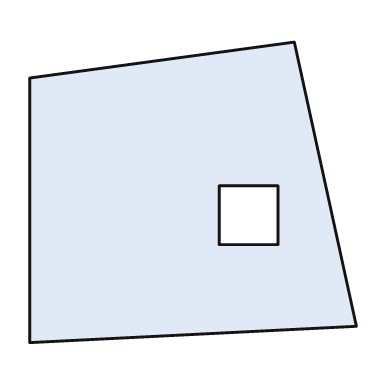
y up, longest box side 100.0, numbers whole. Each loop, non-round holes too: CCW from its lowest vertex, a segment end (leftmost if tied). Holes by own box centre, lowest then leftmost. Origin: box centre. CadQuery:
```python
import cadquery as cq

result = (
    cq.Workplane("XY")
    .moveTo(-50.0, -46.0)
    .lineTo(50.0, -41.0)
    .lineTo(31.0, 46.0)
    .lineTo(-50.0, 35.0)
    .close()
    .moveTo(8.0, -16.0)
    .lineTo(26.0, -16.0)
    .lineTo(26.0, 2.0)
    .lineTo(8.0, 2.0)
    .close()
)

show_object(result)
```